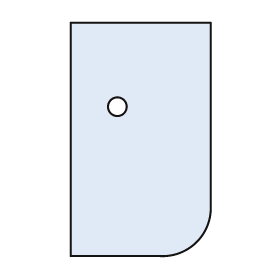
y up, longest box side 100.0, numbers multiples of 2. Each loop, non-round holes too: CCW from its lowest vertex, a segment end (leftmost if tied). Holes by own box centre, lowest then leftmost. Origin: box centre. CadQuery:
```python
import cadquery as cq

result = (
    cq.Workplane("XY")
    .moveTo(-30.0, -50.0)
    .lineTo(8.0, -50.0)
    .threePointArc((24.0, -44.0), (30.0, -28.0))
    .lineTo(30.0, 50.0)
    .lineTo(-30.0, 50.0)
    .close()
    .moveTo(-10.0, 14.0)
    .circle(4.0)
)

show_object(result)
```